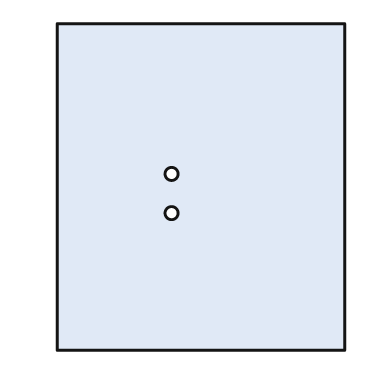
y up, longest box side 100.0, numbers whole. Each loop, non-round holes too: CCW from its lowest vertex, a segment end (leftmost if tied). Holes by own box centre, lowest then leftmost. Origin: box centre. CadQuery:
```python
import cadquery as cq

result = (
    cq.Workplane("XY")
    .moveTo(-44.0, -50.0)
    .lineTo(44.0, -50.0)
    .lineTo(44.0, 50.0)
    .lineTo(-44.0, 50.0)
    .close()
    .moveTo(-9.0, -8.0)
    .circle(2.0)
    .moveTo(-9.0, 4.0)
    .circle(2.0)
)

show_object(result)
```